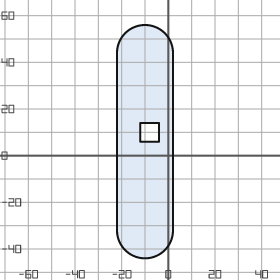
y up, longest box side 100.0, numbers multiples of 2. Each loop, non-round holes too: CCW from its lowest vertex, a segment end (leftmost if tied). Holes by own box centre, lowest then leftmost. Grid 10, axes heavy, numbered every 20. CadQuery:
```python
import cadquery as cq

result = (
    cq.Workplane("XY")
    .moveTo(-22.0, -32.0)
    .threePointArc((-10.0, -44.0), (2.0, -32.0))
    .lineTo(2.0, 44.0)
    .threePointArc((-10.0, 56.0), (-22.0, 44.0))
    .close()
    .moveTo(-12.0, 6.0)
    .lineTo(-4.0, 6.0)
    .lineTo(-4.0, 14.0)
    .lineTo(-12.0, 14.0)
    .close()
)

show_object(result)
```